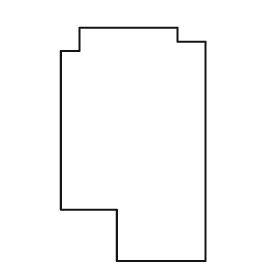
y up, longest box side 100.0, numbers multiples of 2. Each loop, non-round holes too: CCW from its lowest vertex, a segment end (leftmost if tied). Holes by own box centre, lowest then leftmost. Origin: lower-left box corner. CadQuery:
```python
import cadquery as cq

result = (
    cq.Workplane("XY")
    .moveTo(24.0, 0.0)
    .lineTo(62.0, 0.0)
    .lineTo(62.0, 94.0)
    .lineTo(50.0, 94.0)
    .lineTo(50.0, 100.0)
    .lineTo(8.0, 100.0)
    .lineTo(8.0, 90.0)
    .lineTo(0.0, 90.0)
    .lineTo(0.0, 22.0)
    .lineTo(24.0, 22.0)
    .close()
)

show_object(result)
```